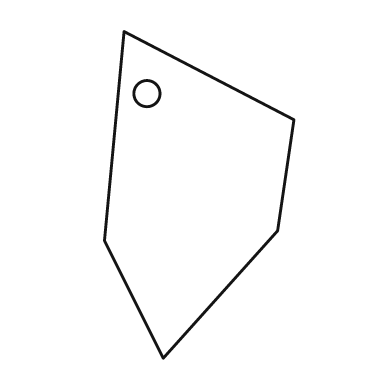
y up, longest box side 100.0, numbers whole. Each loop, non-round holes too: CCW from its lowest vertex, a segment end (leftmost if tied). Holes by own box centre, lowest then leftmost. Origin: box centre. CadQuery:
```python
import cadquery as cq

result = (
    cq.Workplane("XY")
    .moveTo(-11.0, -50.0)
    .lineTo(24.0, -11.0)
    .lineTo(29.0, 23.0)
    .lineTo(-23.0, 50.0)
    .lineTo(-29.0, -14.0)
    .close()
    .moveTo(-16.0, 31.0)
    .circle(4.0)
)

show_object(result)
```